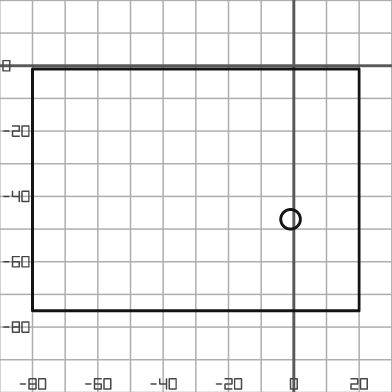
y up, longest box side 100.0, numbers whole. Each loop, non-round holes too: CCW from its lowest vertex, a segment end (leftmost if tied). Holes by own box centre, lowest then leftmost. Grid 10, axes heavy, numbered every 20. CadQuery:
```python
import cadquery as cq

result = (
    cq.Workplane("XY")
    .moveTo(-80.0, -75.0)
    .lineTo(20.0, -75.0)
    .lineTo(20.0, -1.0)
    .lineTo(-80.0, -1.0)
    .close()
    .moveTo(-1.0, -47.0)
    .circle(3.0)
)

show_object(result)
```